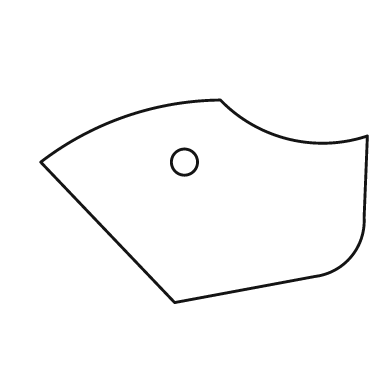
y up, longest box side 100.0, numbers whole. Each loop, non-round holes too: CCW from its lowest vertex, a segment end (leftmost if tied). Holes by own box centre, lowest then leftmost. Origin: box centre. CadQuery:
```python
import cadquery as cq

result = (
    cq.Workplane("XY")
    .moveTo(-9.0, -31.0)
    .lineTo(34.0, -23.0)
    .threePointArc((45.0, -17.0), (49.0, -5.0))
    .lineTo(50.0, 20.0)
    .threePointArc((26.0, 19.0), (5.0, 31.0))
    .threePointArc((-24.0, 26.0), (-50.0, 12.0))
    .close()
    .moveTo(-6.0, 12.0)
    .circle(4.0)
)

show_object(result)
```